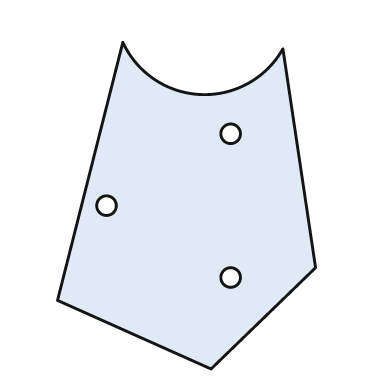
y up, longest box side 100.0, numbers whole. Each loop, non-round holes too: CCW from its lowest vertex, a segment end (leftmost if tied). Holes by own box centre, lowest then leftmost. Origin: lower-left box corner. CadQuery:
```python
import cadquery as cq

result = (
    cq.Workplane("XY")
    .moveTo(47.0, 0.0)
    .lineTo(79.0, 31.0)
    .lineTo(69.0, 98.0)
    .threePointArc((44.0, 84.0), (20.0, 100.0))
    .lineTo(0.0, 21.0)
    .close()
    .moveTo(53.0, 28.0)
    .circle(3.0)
    .moveTo(15.0, 50.0)
    .circle(3.0)
    .moveTo(53.0, 72.0)
    .circle(3.0)
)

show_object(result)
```